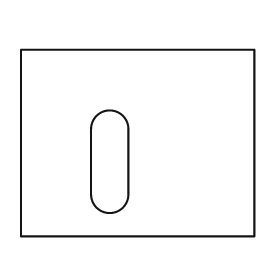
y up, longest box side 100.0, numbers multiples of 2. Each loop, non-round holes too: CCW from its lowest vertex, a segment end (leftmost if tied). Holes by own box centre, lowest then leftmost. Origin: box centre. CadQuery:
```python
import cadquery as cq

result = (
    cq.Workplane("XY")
    .moveTo(-50.0, -40.0)
    .lineTo(50.0, -40.0)
    .lineTo(50.0, 40.0)
    .lineTo(-50.0, 40.0)
    .close()
    .moveTo(-20.0, -22.0)
    .threePointArc((-12.0, -30.0), (-4.0, -22.0))
    .lineTo(-4.0, 6.0)
    .threePointArc((-12.0, 14.0), (-20.0, 6.0))
    .close()
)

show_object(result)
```